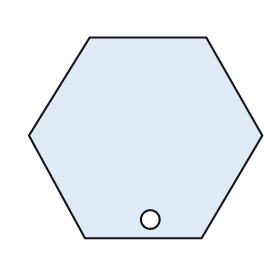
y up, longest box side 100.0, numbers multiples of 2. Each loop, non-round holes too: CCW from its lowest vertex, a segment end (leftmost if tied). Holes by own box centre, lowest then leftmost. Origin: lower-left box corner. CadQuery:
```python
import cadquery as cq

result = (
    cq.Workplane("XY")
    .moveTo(24.0, 0.0)
    .lineTo(74.0, 0.0)
    .lineTo(100.0, 44.0)
    .lineTo(76.0, 86.0)
    .lineTo(26.0, 86.0)
    .lineTo(0.0, 44.0)
    .close()
    .moveTo(52.0, 8.0)
    .circle(4.0)
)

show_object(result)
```